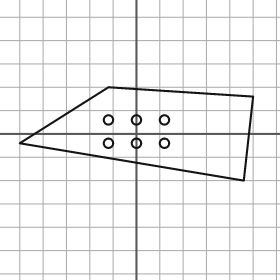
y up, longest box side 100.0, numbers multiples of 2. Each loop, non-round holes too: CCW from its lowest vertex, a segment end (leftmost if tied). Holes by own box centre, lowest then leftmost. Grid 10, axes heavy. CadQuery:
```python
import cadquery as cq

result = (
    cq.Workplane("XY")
    .moveTo(46.0, -20.0)
    .lineTo(50.0, 16.0)
    .lineTo(-12.0, 20.0)
    .lineTo(-50.0, -4.0)
    .close()
    .moveTo(-12.0, -4.0)
    .circle(2.0)
    .moveTo(0.0, -4.0)
    .circle(2.0)
    .moveTo(12.0, -4.0)
    .circle(2.0)
    .moveTo(-12.0, 6.0)
    .circle(2.0)
    .moveTo(0.0, 6.0)
    .circle(2.0)
    .moveTo(12.0, 6.0)
    .circle(2.0)
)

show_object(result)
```